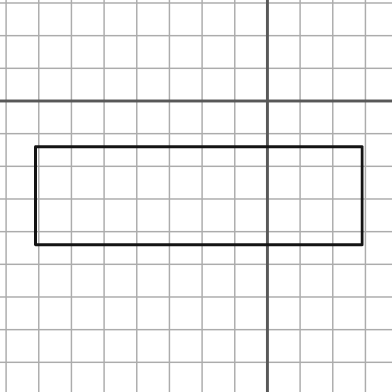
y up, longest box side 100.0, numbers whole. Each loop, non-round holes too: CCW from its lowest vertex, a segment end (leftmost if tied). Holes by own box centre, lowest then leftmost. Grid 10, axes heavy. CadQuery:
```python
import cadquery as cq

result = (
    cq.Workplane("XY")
    .moveTo(-71.0, -44.0)
    .lineTo(29.0, -44.0)
    .lineTo(29.0, -14.0)
    .lineTo(-71.0, -14.0)
    .close()
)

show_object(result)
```